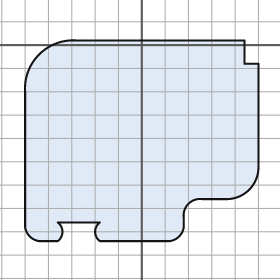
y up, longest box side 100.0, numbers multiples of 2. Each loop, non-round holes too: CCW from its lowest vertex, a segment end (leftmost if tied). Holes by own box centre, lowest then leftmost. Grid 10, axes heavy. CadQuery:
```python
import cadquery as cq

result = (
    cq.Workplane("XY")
    .moveTo(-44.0, -84.0)
    .lineTo(-36.0, -84.0)
    .threePointArc((-34.0, -80.0), (-36.0, -76.0))
    .lineTo(-18.0, -76.0)
    .threePointArc((-20.0, -80.0), (-18.0, -84.0))
    .lineTo(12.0, -84.0)
    .threePointArc((16.0, -82.0), (18.0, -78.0))
    .lineTo(18.0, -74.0)
    .threePointArc((20.0, -68.0), (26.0, -66.0))
    .lineTo(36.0, -66.0)
    .threePointArc((46.0, -62.0), (50.0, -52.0))
    .lineTo(50.0, -8.0)
    .lineTo(44.0, -8.0)
    .lineTo(44.0, 2.0)
    .lineTo(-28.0, 2.0)
    .threePointArc((-44.0, -4.0), (-50.0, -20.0))
    .lineTo(-50.0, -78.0)
    .threePointArc((-48.0, -82.0), (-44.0, -84.0))
    .close()
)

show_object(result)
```